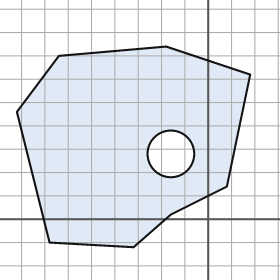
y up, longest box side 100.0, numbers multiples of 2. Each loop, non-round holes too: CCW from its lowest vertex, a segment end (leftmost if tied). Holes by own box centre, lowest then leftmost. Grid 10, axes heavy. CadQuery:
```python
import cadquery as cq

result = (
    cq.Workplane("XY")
    .moveTo(-32.0, -12.0)
    .lineTo(-16.0, 2.0)
    .lineTo(8.0, 14.0)
    .lineTo(18.0, 62.0)
    .lineTo(-18.0, 74.0)
    .lineTo(-64.0, 70.0)
    .lineTo(-82.0, 46.0)
    .lineTo(-68.0, -10.0)
    .close()
    .moveTo(-16.0, 28.0)
    .circle(10.0)
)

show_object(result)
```